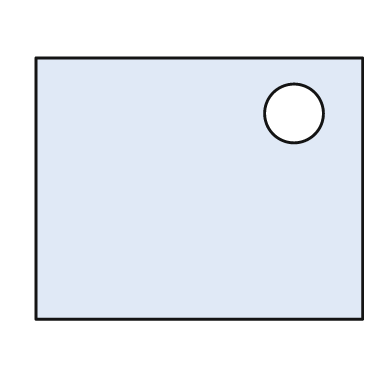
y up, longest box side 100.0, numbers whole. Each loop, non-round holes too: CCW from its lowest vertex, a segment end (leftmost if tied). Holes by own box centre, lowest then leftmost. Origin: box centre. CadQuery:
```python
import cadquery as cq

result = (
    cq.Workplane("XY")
    .moveTo(-50.0, -40.0)
    .lineTo(50.0, -40.0)
    .lineTo(50.0, 40.0)
    .lineTo(-50.0, 40.0)
    .close()
    .moveTo(29.0, 23.0)
    .circle(9.0)
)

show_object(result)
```